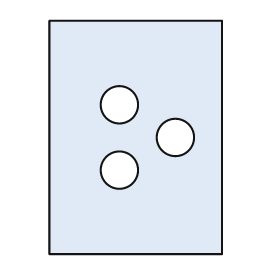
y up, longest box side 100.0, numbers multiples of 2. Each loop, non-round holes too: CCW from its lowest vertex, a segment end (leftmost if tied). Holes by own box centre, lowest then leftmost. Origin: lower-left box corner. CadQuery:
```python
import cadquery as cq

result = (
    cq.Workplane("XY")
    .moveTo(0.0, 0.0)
    .lineTo(74.0, 0.0)
    .lineTo(74.0, 100.0)
    .lineTo(0.0, 100.0)
    .close()
    .moveTo(30.0, 36.0)
    .circle(8.0)
    .moveTo(54.0, 50.0)
    .circle(8.0)
    .moveTo(30.0, 64.0)
    .circle(8.0)
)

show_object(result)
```